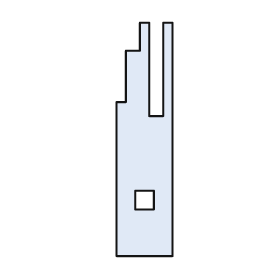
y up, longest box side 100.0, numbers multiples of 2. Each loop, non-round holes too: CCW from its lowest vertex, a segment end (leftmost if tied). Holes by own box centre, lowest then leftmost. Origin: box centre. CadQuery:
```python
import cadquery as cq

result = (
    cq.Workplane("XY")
    .moveTo(-12.0, -50.0)
    .lineTo(12.0, -50.0)
    .lineTo(12.0, 50.0)
    .lineTo(8.0, 50.0)
    .lineTo(8.0, 10.0)
    .lineTo(2.0, 10.0)
    .lineTo(2.0, 50.0)
    .lineTo(-2.0, 50.0)
    .lineTo(-2.0, 38.0)
    .lineTo(-8.0, 38.0)
    .lineTo(-8.0, 16.0)
    .lineTo(-12.0, 16.0)
    .close()
    .moveTo(-4.0, -30.0)
    .lineTo(4.0, -30.0)
    .lineTo(4.0, -22.0)
    .lineTo(-4.0, -22.0)
    .close()
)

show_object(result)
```